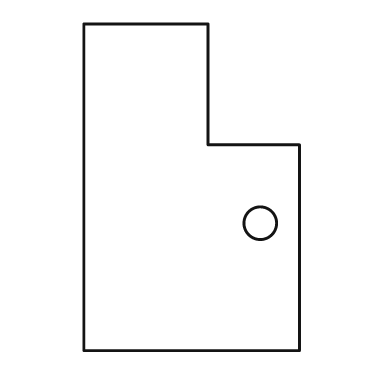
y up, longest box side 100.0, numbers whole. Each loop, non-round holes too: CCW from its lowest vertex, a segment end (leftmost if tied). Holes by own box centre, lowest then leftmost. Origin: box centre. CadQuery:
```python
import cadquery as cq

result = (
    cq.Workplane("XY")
    .moveTo(-33.0, -50.0)
    .lineTo(33.0, -50.0)
    .lineTo(33.0, 13.0)
    .lineTo(5.0, 13.0)
    .lineTo(5.0, 50.0)
    .lineTo(-33.0, 50.0)
    .close()
    .moveTo(21.0, -11.0)
    .circle(5.0)
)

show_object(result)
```